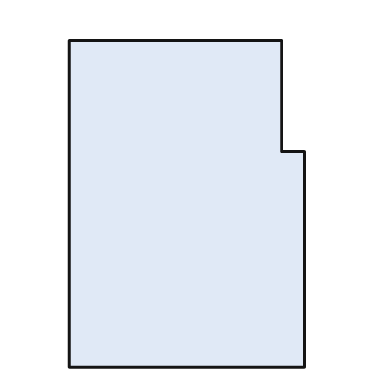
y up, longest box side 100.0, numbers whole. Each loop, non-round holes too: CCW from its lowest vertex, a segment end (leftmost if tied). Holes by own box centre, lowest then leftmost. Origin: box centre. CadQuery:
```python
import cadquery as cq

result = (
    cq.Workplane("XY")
    .moveTo(-36.0, -50.0)
    .lineTo(36.0, -50.0)
    .lineTo(36.0, 16.0)
    .lineTo(29.0, 16.0)
    .lineTo(29.0, 50.0)
    .lineTo(-36.0, 50.0)
    .close()
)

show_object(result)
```